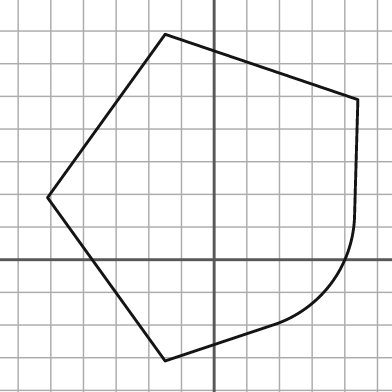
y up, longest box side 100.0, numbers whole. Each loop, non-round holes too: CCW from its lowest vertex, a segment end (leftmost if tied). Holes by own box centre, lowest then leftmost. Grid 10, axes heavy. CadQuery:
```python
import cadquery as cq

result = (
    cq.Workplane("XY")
    .moveTo(-15.0, -31.0)
    .lineTo(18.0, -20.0)
    .threePointArc((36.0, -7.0), (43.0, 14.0))
    .lineTo(44.0, 49.0)
    .lineTo(-15.0, 69.0)
    .lineTo(-51.0, 19.0)
    .close()
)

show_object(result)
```